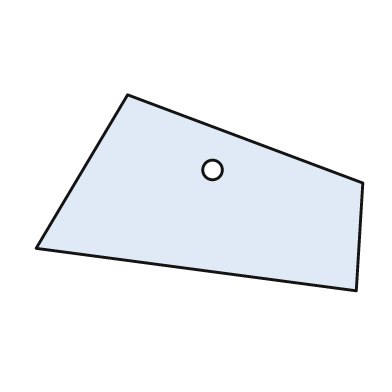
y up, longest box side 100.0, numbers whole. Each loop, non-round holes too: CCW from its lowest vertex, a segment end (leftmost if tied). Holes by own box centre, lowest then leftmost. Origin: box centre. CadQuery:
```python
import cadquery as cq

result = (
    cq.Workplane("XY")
    .moveTo(48.0, -30.0)
    .lineTo(50.0, 3.0)
    .lineTo(-22.0, 30.0)
    .lineTo(-50.0, -17.0)
    .close()
    .moveTo(4.0, 7.0)
    .circle(3.0)
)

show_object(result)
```